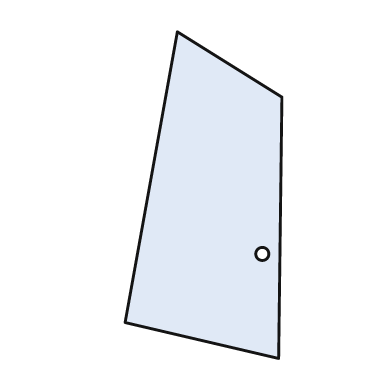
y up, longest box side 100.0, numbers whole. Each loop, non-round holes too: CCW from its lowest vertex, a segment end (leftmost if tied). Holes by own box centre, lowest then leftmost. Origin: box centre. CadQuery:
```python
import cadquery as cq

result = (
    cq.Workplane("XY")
    .moveTo(23.0, -50.0)
    .lineTo(24.0, 30.0)
    .lineTo(-8.0, 50.0)
    .lineTo(-24.0, -39.0)
    .close()
    .moveTo(18.0, -18.0)
    .circle(2.0)
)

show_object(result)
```